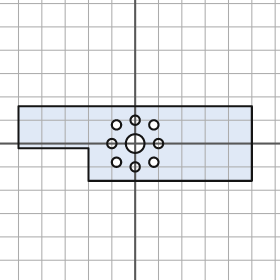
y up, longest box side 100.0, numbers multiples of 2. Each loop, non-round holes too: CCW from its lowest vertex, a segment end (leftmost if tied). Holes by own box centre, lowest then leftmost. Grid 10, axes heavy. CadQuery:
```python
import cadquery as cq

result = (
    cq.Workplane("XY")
    .moveTo(-20.0, -16.0)
    .lineTo(50.0, -16.0)
    .lineTo(50.0, 16.0)
    .lineTo(-50.0, 16.0)
    .lineTo(-50.0, -2.0)
    .lineTo(-20.0, -2.0)
    .close()
    .moveTo(0.0, -10.0)
    .circle(2.0)
    .moveTo(-8.0, -8.0)
    .circle(2.0)
    .moveTo(8.0, -8.0)
    .circle(2.0)
    .moveTo(-10.0, 0.0)
    .circle(2.0)
    .moveTo(0.0, 0.0)
    .circle(4.0)
    .moveTo(10.0, 0.0)
    .circle(2.0)
    .moveTo(-8.0, 8.0)
    .circle(2.0)
    .moveTo(8.0, 8.0)
    .circle(2.0)
    .moveTo(0.0, 10.0)
    .circle(2.0)
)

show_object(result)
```